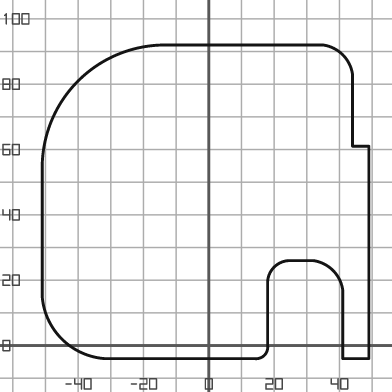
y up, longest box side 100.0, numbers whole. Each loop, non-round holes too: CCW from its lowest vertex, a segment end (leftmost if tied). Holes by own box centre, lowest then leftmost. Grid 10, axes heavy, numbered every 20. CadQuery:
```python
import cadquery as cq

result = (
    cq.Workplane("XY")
    .moveTo(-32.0, -4.0)
    .lineTo(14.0, -4.0)
    .threePointArc((17.0, -3.0), (18.0, 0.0))
    .lineTo(18.0, 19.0)
    .threePointArc((20.0, 24.0), (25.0, 26.0))
    .lineTo(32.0, 26.0)
    .threePointArc((38.0, 23.0), (41.0, 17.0))
    .lineTo(41.0, -4.0)
    .lineTo(49.0, -4.0)
    .lineTo(49.0, 61.0)
    .lineTo(44.0, 61.0)
    .lineTo(44.0, 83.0)
    .threePointArc((41.0, 89.0), (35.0, 92.0))
    .lineTo(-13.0, 92.0)
    .threePointArc((-40.0, 81.0), (-51.0, 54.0))
    .lineTo(-51.0, 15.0)
    .threePointArc((-45.0, 2.0), (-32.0, -4.0))
    .close()
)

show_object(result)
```